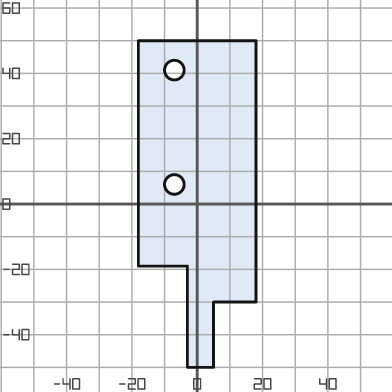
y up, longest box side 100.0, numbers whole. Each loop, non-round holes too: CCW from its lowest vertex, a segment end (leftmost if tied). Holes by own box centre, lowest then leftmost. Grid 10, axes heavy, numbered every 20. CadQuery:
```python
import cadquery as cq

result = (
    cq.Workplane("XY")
    .moveTo(-3.0, -50.0)
    .lineTo(5.0, -50.0)
    .lineTo(5.0, -30.0)
    .lineTo(18.0, -30.0)
    .lineTo(18.0, 50.0)
    .lineTo(-18.0, 50.0)
    .lineTo(-18.0, -19.0)
    .lineTo(-3.0, -19.0)
    .close()
    .moveTo(-7.0, 6.0)
    .circle(3.0)
    .moveTo(-7.0, 41.0)
    .circle(3.0)
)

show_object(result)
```